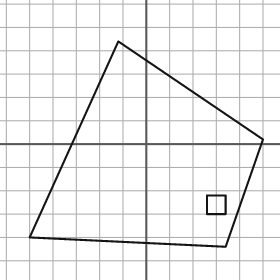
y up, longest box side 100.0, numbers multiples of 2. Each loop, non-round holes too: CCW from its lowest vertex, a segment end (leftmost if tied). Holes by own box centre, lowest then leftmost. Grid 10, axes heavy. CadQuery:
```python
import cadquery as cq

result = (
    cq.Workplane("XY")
    .moveTo(34.0, -44.0)
    .lineTo(50.0, 2.0)
    .lineTo(-12.0, 44.0)
    .lineTo(-50.0, -40.0)
    .close()
    .moveTo(26.0, -30.0)
    .lineTo(34.0, -30.0)
    .lineTo(34.0, -22.0)
    .lineTo(26.0, -22.0)
    .close()
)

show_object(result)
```